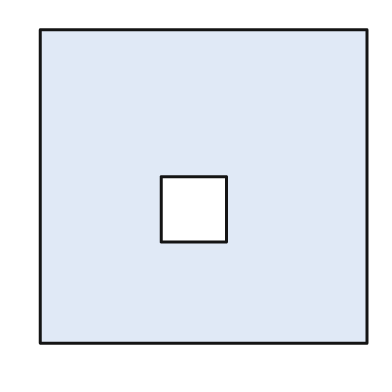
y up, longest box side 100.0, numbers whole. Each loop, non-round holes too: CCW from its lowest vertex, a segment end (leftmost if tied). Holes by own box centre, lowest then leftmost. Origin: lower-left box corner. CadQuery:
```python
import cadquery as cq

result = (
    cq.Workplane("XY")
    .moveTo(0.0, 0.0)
    .lineTo(100.0, 0.0)
    .lineTo(100.0, 96.0)
    .lineTo(0.0, 96.0)
    .close()
    .moveTo(37.0, 31.0)
    .lineTo(57.0, 31.0)
    .lineTo(57.0, 51.0)
    .lineTo(37.0, 51.0)
    .close()
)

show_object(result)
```